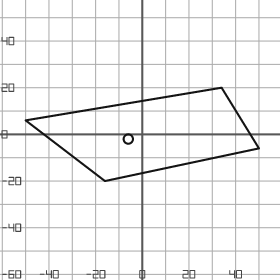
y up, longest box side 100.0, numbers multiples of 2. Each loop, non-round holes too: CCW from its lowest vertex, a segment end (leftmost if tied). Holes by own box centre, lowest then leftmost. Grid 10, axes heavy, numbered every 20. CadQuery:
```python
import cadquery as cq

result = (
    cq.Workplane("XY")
    .moveTo(-16.0, -20.0)
    .lineTo(50.0, -6.0)
    .lineTo(34.0, 20.0)
    .lineTo(-50.0, 6.0)
    .close()
    .moveTo(-6.0, -2.0)
    .circle(2.0)
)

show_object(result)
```